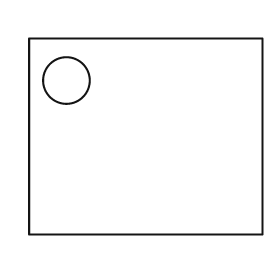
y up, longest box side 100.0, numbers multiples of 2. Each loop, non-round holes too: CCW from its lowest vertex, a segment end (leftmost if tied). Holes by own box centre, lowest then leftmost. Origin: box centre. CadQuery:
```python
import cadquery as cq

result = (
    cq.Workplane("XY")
    .moveTo(-50.0, -42.0)
    .lineTo(50.0, -42.0)
    .lineTo(50.0, 42.0)
    .lineTo(-50.0, 42.0)
    .close()
    .moveTo(-34.0, 24.0)
    .circle(10.0)
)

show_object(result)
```